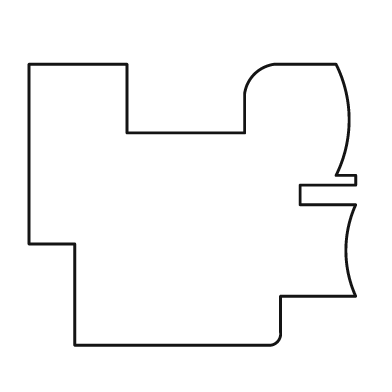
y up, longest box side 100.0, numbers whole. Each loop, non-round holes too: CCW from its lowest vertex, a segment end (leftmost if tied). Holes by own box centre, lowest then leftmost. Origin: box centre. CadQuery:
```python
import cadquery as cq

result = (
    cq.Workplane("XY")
    .moveTo(-36.0, -43.0)
    .lineTo(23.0, -43.0)
    .threePointArc((26.0, -42.0), (27.0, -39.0))
    .lineTo(27.0, -28.0)
    .lineTo(50.0, -28.0)
    .threePointArc((47.0, -14.0), (50.0, 0.0))
    .lineTo(33.0, 0.0)
    .lineTo(33.0, 6.0)
    .lineTo(50.0, 6.0)
    .lineTo(50.0, 9.0)
    .lineTo(44.0, 9.0)
    .threePointArc((48.0, 26.0), (44.0, 43.0))
    .lineTo(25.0, 43.0)
    .threePointArc((19.0, 40.0), (16.0, 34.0))
    .lineTo(16.0, 22.0)
    .lineTo(-20.0, 22.0)
    .lineTo(-20.0, 43.0)
    .lineTo(-50.0, 43.0)
    .lineTo(-50.0, -12.0)
    .lineTo(-36.0, -12.0)
    .close()
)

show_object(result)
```